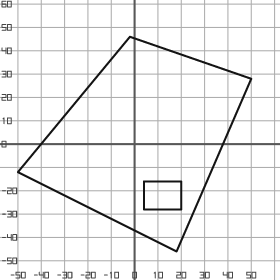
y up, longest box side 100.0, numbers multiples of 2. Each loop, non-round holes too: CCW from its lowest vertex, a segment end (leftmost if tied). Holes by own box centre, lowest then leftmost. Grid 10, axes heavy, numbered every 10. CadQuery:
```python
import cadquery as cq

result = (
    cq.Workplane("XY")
    .moveTo(18.0, -46.0)
    .lineTo(50.0, 28.0)
    .lineTo(-2.0, 46.0)
    .lineTo(-50.0, -12.0)
    .close()
    .moveTo(4.0, -28.0)
    .lineTo(20.0, -28.0)
    .lineTo(20.0, -16.0)
    .lineTo(4.0, -16.0)
    .close()
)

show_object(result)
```